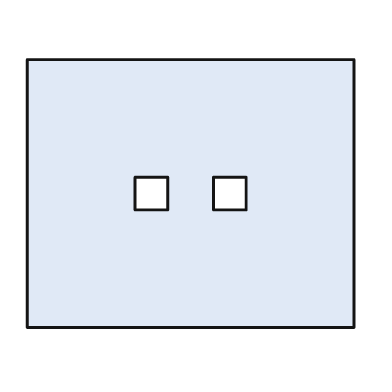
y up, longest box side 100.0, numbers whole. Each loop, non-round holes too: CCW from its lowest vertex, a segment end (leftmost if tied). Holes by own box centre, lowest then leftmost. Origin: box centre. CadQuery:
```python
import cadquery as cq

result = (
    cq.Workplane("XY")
    .moveTo(-50.0, -41.0)
    .lineTo(50.0, -41.0)
    .lineTo(50.0, 41.0)
    .lineTo(-50.0, 41.0)
    .close()
    .moveTo(-17.0, -5.0)
    .lineTo(-7.0, -5.0)
    .lineTo(-7.0, 5.0)
    .lineTo(-17.0, 5.0)
    .close()
    .moveTo(7.0, -5.0)
    .lineTo(17.0, -5.0)
    .lineTo(17.0, 5.0)
    .lineTo(7.0, 5.0)
    .close()
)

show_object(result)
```